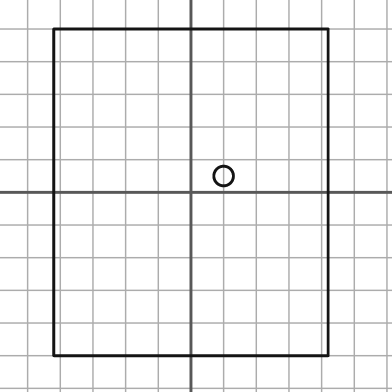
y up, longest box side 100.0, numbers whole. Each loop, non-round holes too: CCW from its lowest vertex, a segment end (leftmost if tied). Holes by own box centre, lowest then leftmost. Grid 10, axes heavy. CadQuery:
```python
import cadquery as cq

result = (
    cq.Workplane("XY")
    .moveTo(-42.0, -50.0)
    .lineTo(42.0, -50.0)
    .lineTo(42.0, 50.0)
    .lineTo(-42.0, 50.0)
    .close()
    .moveTo(10.0, 5.0)
    .circle(3.0)
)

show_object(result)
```